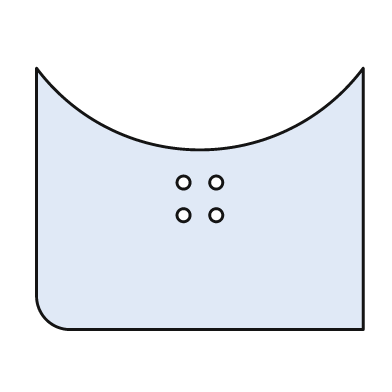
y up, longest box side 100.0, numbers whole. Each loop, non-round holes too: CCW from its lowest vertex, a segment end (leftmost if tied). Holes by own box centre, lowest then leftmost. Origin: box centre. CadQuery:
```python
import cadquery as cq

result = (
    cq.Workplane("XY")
    .moveTo(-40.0, -40.0)
    .lineTo(50.0, -40.0)
    .lineTo(50.0, 40.0)
    .threePointArc((0.0, 15.0), (-50.0, 40.0))
    .lineTo(-50.0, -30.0)
    .threePointArc((-47.0, -37.0), (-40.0, -40.0))
    .close()
    .moveTo(-5.0, -5.0)
    .circle(2.0)
    .moveTo(5.0, -5.0)
    .circle(2.0)
    .moveTo(-5.0, 5.0)
    .circle(2.0)
    .moveTo(5.0, 5.0)
    .circle(2.0)
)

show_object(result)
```